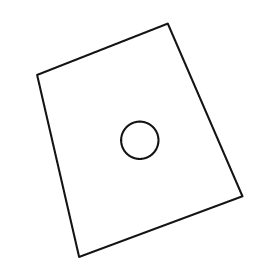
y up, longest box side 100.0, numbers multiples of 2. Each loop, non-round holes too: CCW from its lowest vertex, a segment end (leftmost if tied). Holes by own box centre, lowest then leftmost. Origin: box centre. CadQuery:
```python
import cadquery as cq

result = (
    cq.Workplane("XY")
    .moveTo(-26.0, -50.0)
    .lineTo(44.0, -24.0)
    .lineTo(12.0, 50.0)
    .lineTo(-44.0, 28.0)
    .close()
    .moveTo(0.0, 0.0)
    .circle(8.0)
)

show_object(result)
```